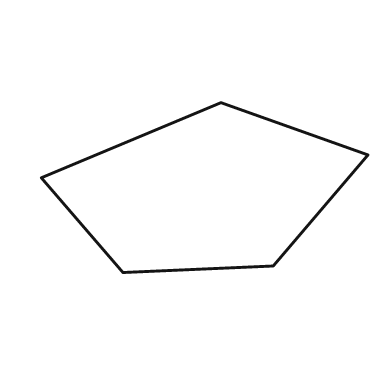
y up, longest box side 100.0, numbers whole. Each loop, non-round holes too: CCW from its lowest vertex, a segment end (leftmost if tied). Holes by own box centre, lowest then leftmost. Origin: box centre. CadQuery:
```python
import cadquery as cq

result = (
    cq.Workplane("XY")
    .moveTo(-25.0, -26.0)
    .lineTo(21.0, -24.0)
    .lineTo(50.0, 10.0)
    .lineTo(5.0, 26.0)
    .lineTo(-50.0, 3.0)
    .close()
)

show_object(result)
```